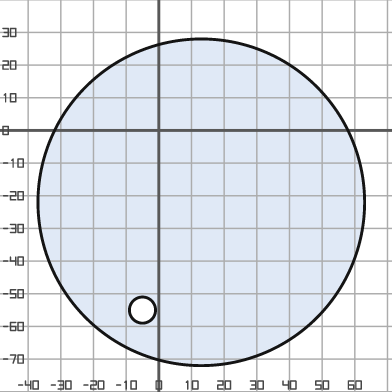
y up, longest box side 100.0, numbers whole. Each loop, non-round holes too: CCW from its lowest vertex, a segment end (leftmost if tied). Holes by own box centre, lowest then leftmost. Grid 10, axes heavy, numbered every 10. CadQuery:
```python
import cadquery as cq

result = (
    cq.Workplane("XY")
    .moveTo(13.0, -22.0)
    .circle(50.0)
    .moveTo(-5.0, -55.0)
    .circle(4.0)
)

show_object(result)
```